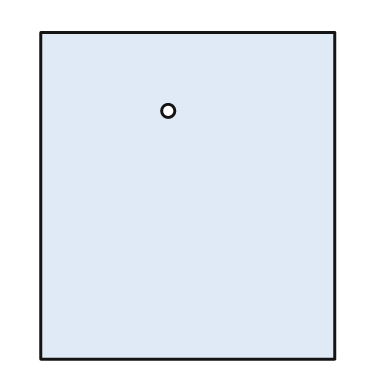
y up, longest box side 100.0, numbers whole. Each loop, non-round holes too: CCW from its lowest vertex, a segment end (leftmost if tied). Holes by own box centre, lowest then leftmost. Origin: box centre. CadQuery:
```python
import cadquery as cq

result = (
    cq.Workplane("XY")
    .moveTo(-45.0, -50.0)
    .lineTo(45.0, -50.0)
    .lineTo(45.0, 50.0)
    .lineTo(-45.0, 50.0)
    .close()
    .moveTo(-6.0, 26.0)
    .circle(2.0)
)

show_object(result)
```